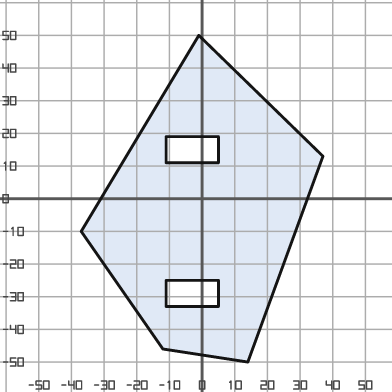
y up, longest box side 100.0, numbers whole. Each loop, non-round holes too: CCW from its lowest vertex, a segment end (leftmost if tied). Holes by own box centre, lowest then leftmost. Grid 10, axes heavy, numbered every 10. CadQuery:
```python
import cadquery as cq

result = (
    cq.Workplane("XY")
    .moveTo(14.0, -50.0)
    .lineTo(37.0, 13.0)
    .lineTo(-1.0, 50.0)
    .lineTo(-37.0, -10.0)
    .lineTo(-12.0, -46.0)
    .close()
    .moveTo(-11.0, -33.0)
    .lineTo(5.0, -33.0)
    .lineTo(5.0, -25.0)
    .lineTo(-11.0, -25.0)
    .close()
    .moveTo(-11.0, 11.0)
    .lineTo(5.0, 11.0)
    .lineTo(5.0, 19.0)
    .lineTo(-11.0, 19.0)
    .close()
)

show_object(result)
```